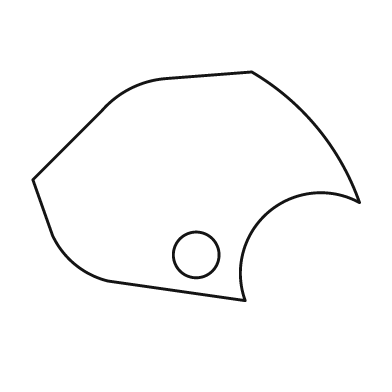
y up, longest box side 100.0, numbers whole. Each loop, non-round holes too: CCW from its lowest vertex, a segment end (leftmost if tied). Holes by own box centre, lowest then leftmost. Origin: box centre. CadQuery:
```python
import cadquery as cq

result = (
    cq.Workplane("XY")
    .moveTo(15.0, -35.0)
    .threePointArc((22.0, -8.0), (50.0, -5.0))
    .threePointArc((37.0, 18.0), (17.0, 35.0))
    .lineTo(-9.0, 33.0)
    .threePointArc((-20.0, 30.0), (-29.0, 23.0))
    .lineTo(-50.0, 2.0)
    .lineTo(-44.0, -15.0)
    .threePointArc((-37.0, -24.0), (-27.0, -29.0))
    .close()
    .moveTo(0.0, -21.0)
    .circle(7.0)
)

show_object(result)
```